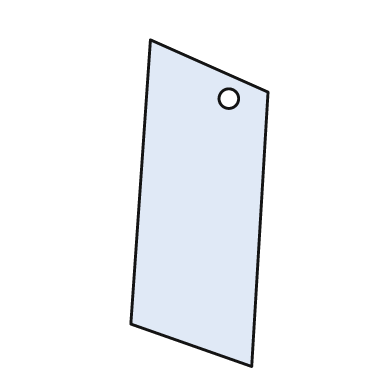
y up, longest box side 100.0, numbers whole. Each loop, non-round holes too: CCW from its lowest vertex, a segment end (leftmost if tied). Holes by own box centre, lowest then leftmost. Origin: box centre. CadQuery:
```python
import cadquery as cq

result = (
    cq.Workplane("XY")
    .moveTo(16.0, -50.0)
    .lineTo(21.0, 34.0)
    .lineTo(-15.0, 50.0)
    .lineTo(-21.0, -37.0)
    .close()
    .moveTo(9.0, 32.0)
    .circle(3.0)
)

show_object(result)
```